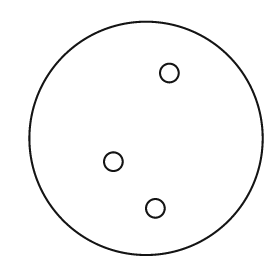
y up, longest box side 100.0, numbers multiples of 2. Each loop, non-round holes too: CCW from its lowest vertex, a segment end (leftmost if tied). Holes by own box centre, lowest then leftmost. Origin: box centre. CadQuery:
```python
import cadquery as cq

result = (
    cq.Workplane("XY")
    .moveTo(0.0, 0.0)
    .circle(50.0)
    .moveTo(4.0, -30.0)
    .circle(4.0)
    .moveTo(-14.0, -10.0)
    .circle(4.0)
    .moveTo(10.0, 28.0)
    .circle(4.0)
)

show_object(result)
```